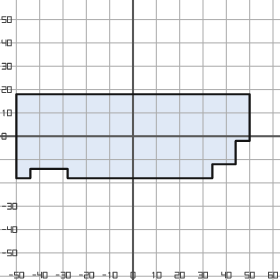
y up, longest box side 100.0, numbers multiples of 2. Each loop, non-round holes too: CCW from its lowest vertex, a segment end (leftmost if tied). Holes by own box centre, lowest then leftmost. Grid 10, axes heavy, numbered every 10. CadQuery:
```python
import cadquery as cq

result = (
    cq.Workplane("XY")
    .moveTo(-50.0, -18.0)
    .lineTo(-44.0, -18.0)
    .lineTo(-44.0, -14.0)
    .lineTo(-28.0, -14.0)
    .lineTo(-28.0, -18.0)
    .lineTo(34.0, -18.0)
    .lineTo(34.0, -12.0)
    .lineTo(44.0, -12.0)
    .lineTo(44.0, -2.0)
    .lineTo(50.0, -2.0)
    .lineTo(50.0, 18.0)
    .lineTo(-50.0, 18.0)
    .close()
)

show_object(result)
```